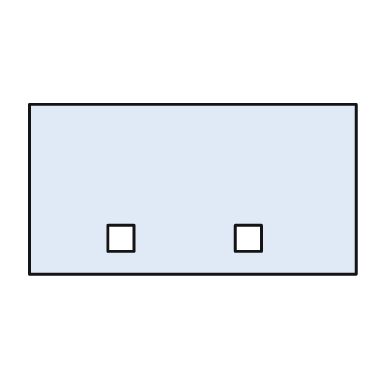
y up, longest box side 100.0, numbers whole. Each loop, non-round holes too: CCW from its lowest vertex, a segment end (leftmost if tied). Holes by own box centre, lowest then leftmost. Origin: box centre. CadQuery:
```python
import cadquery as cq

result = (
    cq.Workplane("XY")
    .moveTo(-50.0, -26.0)
    .lineTo(50.0, -26.0)
    .lineTo(50.0, 26.0)
    .lineTo(-50.0, 26.0)
    .close()
    .moveTo(-26.0, -19.0)
    .lineTo(-18.0, -19.0)
    .lineTo(-18.0, -11.0)
    .lineTo(-26.0, -11.0)
    .close()
    .moveTo(13.0, -19.0)
    .lineTo(21.0, -19.0)
    .lineTo(21.0, -11.0)
    .lineTo(13.0, -11.0)
    .close()
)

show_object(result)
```